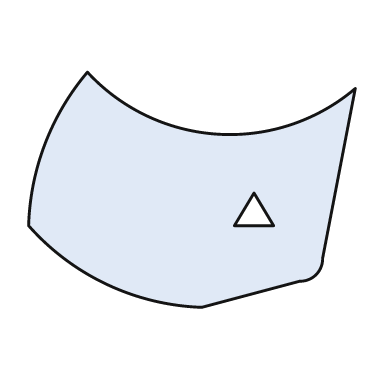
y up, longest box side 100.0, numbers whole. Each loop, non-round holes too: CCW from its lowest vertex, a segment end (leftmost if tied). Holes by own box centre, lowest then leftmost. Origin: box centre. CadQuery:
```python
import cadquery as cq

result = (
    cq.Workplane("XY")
    .moveTo(3.0, -36.0)
    .lineTo(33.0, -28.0)
    .threePointArc((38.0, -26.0), (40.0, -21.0))
    .lineTo(50.0, 31.0)
    .threePointArc((8.0, 17.0), (-32.0, 36.0))
    .threePointArc((-45.0, 14.0), (-50.0, -11.0))
    .threePointArc((-26.0, -29.0), (3.0, -36.0))
    .close()
    .moveTo(13.0, -11.0)
    .lineTo(25.0, -11.0)
    .lineTo(19.0, -1.0)
    .close()
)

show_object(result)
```